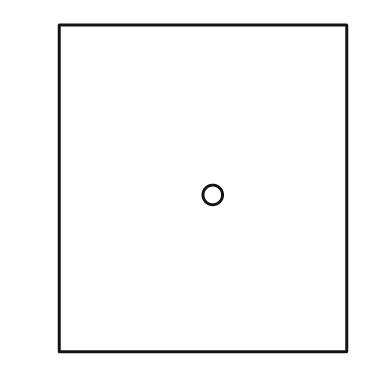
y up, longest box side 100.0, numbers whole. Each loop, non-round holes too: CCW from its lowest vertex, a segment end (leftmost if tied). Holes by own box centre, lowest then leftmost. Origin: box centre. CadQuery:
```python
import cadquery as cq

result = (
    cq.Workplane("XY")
    .moveTo(-44.0, -50.0)
    .lineTo(44.0, -50.0)
    .lineTo(44.0, 50.0)
    .lineTo(-44.0, 50.0)
    .close()
    .moveTo(3.0, -2.0)
    .circle(3.0)
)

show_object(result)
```